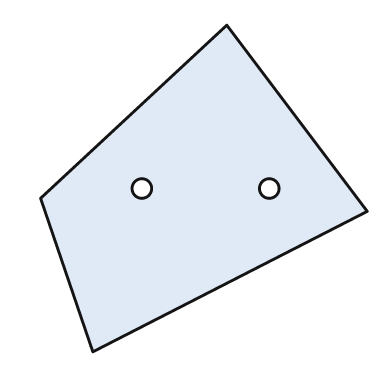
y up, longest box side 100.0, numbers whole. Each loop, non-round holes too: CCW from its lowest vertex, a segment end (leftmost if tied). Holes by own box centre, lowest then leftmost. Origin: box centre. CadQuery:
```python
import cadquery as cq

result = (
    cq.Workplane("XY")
    .moveTo(-34.0, -50.0)
    .lineTo(50.0, -7.0)
    .lineTo(7.0, 50.0)
    .lineTo(-50.0, -3.0)
    .close()
    .moveTo(-19.0, 0.0)
    .circle(3.0)
    .moveTo(20.0, 0.0)
    .circle(3.0)
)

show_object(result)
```